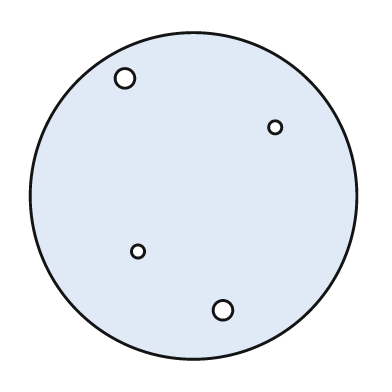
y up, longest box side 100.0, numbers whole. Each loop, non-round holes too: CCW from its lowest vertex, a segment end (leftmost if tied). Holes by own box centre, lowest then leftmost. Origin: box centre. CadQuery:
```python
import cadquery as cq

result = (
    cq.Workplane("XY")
    .moveTo(0.0, 0.0)
    .circle(50.0)
    .moveTo(9.0, -35.0)
    .circle(3.0)
    .moveTo(-17.0, -17.0)
    .circle(2.0)
    .moveTo(25.0, 21.0)
    .circle(2.0)
    .moveTo(-21.0, 36.0)
    .circle(3.0)
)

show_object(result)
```